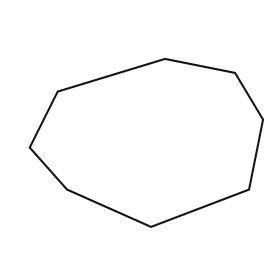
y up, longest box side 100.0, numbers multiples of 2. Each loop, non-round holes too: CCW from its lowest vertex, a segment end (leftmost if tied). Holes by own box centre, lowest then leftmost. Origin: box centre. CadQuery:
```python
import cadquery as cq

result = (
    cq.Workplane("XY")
    .moveTo(2.0, -36.0)
    .lineTo(44.0, -20.0)
    .lineTo(50.0, 10.0)
    .lineTo(38.0, 30.0)
    .lineTo(8.0, 36.0)
    .lineTo(-38.0, 22.0)
    .lineTo(-50.0, -2.0)
    .lineTo(-34.0, -20.0)
    .close()
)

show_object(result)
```